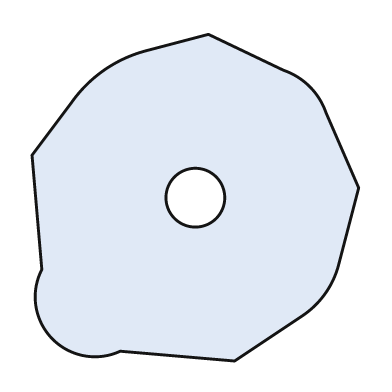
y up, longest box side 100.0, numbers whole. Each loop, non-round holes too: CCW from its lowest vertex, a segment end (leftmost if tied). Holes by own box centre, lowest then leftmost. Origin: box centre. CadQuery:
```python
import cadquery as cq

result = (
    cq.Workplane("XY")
    .moveTo(12.0, -50.0)
    .lineTo(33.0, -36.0)
    .threePointArc((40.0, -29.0), (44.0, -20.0))
    .lineTo(50.0, 3.0)
    .lineTo(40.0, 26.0)
    .threePointArc((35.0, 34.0), (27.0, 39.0))
    .lineTo(4.0, 50.0)
    .lineTo(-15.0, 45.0)
    .threePointArc((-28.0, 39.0), (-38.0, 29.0))
    .lineTo(-50.0, 13.0)
    .lineTo(-47.0, -22.0)
    .threePointArc((-44.0, -43.0), (-23.0, -47.0))
    .close()
    .moveTo(0.0, 0.0)
    .circle(9.0)
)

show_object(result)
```